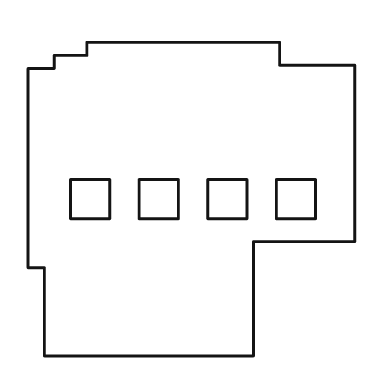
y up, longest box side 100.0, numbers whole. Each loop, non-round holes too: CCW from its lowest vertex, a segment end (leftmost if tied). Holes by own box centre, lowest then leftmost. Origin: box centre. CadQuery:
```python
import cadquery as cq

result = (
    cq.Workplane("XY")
    .moveTo(-45.0, -48.0)
    .lineTo(19.0, -48.0)
    .lineTo(19.0, -13.0)
    .lineTo(50.0, -13.0)
    .lineTo(50.0, 41.0)
    .lineTo(27.0, 41.0)
    .lineTo(27.0, 48.0)
    .lineTo(-32.0, 48.0)
    .lineTo(-32.0, 44.0)
    .lineTo(-42.0, 44.0)
    .lineTo(-42.0, 40.0)
    .lineTo(-50.0, 40.0)
    .lineTo(-50.0, -21.0)
    .lineTo(-45.0, -21.0)
    .close()
    .moveTo(-37.0, -6.0)
    .lineTo(-25.0, -6.0)
    .lineTo(-25.0, 6.0)
    .lineTo(-37.0, 6.0)
    .close()
    .moveTo(-16.0, -6.0)
    .lineTo(-4.0, -6.0)
    .lineTo(-4.0, 6.0)
    .lineTo(-16.0, 6.0)
    .close()
    .moveTo(5.0, -6.0)
    .lineTo(17.0, -6.0)
    .lineTo(17.0, 6.0)
    .lineTo(5.0, 6.0)
    .close()
    .moveTo(26.0, -6.0)
    .lineTo(38.0, -6.0)
    .lineTo(38.0, 6.0)
    .lineTo(26.0, 6.0)
    .close()
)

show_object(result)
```